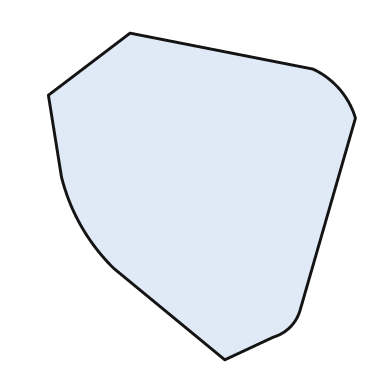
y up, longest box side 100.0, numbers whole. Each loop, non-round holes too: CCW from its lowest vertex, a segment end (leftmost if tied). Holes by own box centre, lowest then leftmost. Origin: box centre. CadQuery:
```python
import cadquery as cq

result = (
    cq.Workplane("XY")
    .moveTo(7.0, -50.0)
    .lineTo(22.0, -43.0)
    .threePointArc((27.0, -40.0), (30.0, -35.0))
    .lineTo(47.0, 24.0)
    .threePointArc((42.0, 33.0), (34.0, 39.0))
    .lineTo(-22.0, 50.0)
    .lineTo(-47.0, 31.0)
    .lineTo(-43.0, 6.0)
    .threePointArc((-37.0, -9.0), (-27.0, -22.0))
    .close()
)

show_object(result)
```